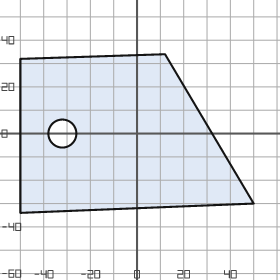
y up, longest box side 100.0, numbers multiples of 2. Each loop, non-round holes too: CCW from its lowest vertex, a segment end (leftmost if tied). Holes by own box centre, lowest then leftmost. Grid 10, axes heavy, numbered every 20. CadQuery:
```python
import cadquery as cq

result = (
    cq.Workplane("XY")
    .moveTo(-50.0, -34.0)
    .lineTo(50.0, -30.0)
    .lineTo(12.0, 34.0)
    .lineTo(-50.0, 32.0)
    .close()
    .moveTo(-32.0, 0.0)
    .circle(6.0)
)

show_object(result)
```